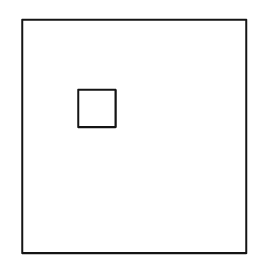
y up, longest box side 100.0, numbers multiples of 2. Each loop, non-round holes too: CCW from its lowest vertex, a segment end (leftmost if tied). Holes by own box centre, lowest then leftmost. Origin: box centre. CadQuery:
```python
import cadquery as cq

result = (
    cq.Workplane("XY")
    .moveTo(-48.0, -50.0)
    .lineTo(48.0, -50.0)
    .lineTo(48.0, 50.0)
    .lineTo(-48.0, 50.0)
    .close()
    .moveTo(-24.0, 4.0)
    .lineTo(-8.0, 4.0)
    .lineTo(-8.0, 20.0)
    .lineTo(-24.0, 20.0)
    .close()
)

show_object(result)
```